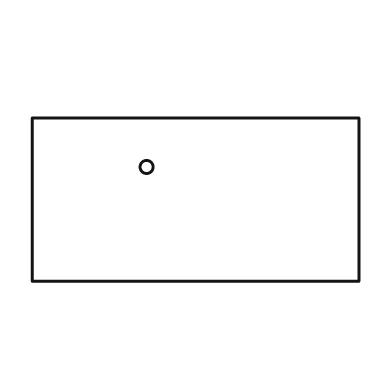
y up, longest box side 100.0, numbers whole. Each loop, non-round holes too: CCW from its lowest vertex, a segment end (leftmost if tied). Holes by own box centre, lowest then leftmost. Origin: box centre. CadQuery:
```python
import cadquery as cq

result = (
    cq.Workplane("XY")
    .moveTo(-50.0, -25.0)
    .lineTo(50.0, -25.0)
    .lineTo(50.0, 25.0)
    .lineTo(-50.0, 25.0)
    .close()
    .moveTo(-15.0, 10.0)
    .circle(2.0)
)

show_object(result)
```